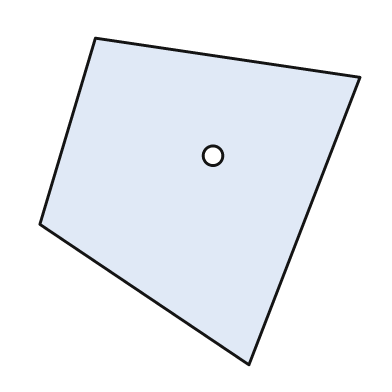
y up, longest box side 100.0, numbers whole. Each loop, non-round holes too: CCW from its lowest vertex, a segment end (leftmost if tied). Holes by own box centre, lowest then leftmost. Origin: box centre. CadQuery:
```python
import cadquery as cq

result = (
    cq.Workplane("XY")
    .moveTo(15.0, -50.0)
    .lineTo(49.0, 38.0)
    .lineTo(-32.0, 50.0)
    .lineTo(-49.0, -7.0)
    .close()
    .moveTo(4.0, 14.0)
    .circle(3.0)
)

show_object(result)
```